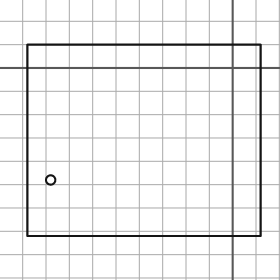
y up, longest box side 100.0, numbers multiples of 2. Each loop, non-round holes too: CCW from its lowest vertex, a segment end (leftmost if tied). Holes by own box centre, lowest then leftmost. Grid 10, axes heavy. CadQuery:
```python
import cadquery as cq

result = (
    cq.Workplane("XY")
    .moveTo(-88.0, -72.0)
    .lineTo(12.0, -72.0)
    .lineTo(12.0, 10.0)
    .lineTo(-88.0, 10.0)
    .close()
    .moveTo(-78.0, -48.0)
    .circle(2.0)
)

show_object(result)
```